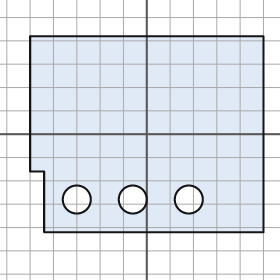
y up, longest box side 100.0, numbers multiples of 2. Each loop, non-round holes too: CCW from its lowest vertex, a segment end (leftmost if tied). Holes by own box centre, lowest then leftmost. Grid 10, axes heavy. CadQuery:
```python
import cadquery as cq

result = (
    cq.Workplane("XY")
    .moveTo(-44.0, -42.0)
    .lineTo(50.0, -42.0)
    .lineTo(50.0, 42.0)
    .lineTo(-50.0, 42.0)
    .lineTo(-50.0, -16.0)
    .lineTo(-44.0, -16.0)
    .close()
    .moveTo(-30.0, -28.0)
    .circle(6.0)
    .moveTo(-6.0, -28.0)
    .circle(6.0)
    .moveTo(18.0, -28.0)
    .circle(6.0)
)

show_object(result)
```